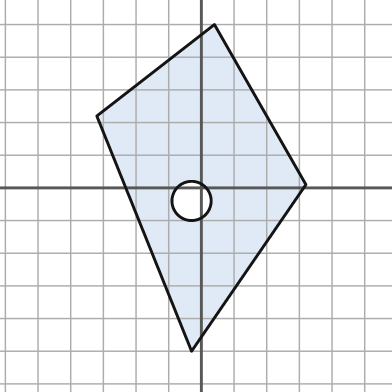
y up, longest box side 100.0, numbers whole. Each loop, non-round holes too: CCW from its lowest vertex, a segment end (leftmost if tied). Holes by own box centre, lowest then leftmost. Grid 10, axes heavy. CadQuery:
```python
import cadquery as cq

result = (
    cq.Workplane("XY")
    .moveTo(-3.0, -50.0)
    .lineTo(32.0, 1.0)
    .lineTo(4.0, 50.0)
    .lineTo(-32.0, 22.0)
    .close()
    .moveTo(-3.0, -4.0)
    .circle(6.0)
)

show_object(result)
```